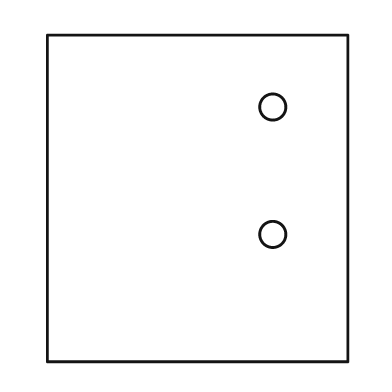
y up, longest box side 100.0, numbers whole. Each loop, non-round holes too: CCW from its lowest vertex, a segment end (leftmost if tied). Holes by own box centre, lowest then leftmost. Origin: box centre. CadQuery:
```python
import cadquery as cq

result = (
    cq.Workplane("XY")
    .moveTo(-46.0, -50.0)
    .lineTo(46.0, -50.0)
    .lineTo(46.0, 50.0)
    .lineTo(-46.0, 50.0)
    .close()
    .moveTo(23.0, -11.0)
    .circle(4.0)
    .moveTo(23.0, 28.0)
    .circle(4.0)
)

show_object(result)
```